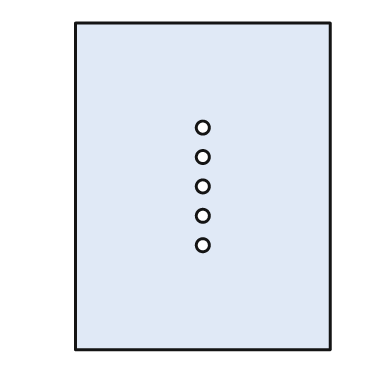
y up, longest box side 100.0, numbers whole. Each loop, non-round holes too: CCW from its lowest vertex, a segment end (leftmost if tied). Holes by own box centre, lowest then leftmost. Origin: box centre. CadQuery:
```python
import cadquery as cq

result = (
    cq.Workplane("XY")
    .moveTo(-39.0, -50.0)
    .lineTo(39.0, -50.0)
    .lineTo(39.0, 50.0)
    .lineTo(-39.0, 50.0)
    .close()
    .moveTo(0.0, -18.0)
    .circle(2.0)
    .moveTo(0.0, -9.0)
    .circle(2.0)
    .moveTo(0.0, 0.0)
    .circle(2.0)
    .moveTo(0.0, 9.0)
    .circle(2.0)
    .moveTo(0.0, 18.0)
    .circle(2.0)
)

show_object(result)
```